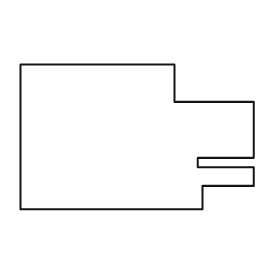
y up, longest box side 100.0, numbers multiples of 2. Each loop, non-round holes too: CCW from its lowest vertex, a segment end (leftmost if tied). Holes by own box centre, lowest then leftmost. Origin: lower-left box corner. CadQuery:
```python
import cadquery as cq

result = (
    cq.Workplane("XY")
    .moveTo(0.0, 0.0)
    .lineTo(78.0, 0.0)
    .lineTo(78.0, 10.0)
    .lineTo(100.0, 10.0)
    .lineTo(100.0, 18.0)
    .lineTo(76.0, 18.0)
    .lineTo(76.0, 22.0)
    .lineTo(100.0, 22.0)
    .lineTo(100.0, 46.0)
    .lineTo(66.0, 46.0)
    .lineTo(66.0, 62.0)
    .lineTo(0.0, 62.0)
    .close()
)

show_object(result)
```